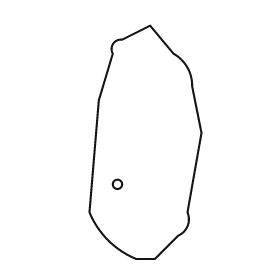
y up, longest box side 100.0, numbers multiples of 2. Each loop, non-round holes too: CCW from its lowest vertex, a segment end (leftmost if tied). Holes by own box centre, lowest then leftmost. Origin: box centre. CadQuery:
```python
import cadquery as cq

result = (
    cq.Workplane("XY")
    .moveTo(-4.0, -50.0)
    .lineTo(4.0, -50.0)
    .lineTo(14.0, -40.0)
    .threePointArc((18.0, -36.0), (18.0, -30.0))
    .lineTo(24.0, 4.0)
    .lineTo(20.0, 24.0)
    .threePointArc((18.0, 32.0), (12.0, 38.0))
    .lineTo(2.0, 50.0)
    .lineTo(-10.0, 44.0)
    .threePointArc((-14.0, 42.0), (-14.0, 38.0))
    .lineTo(-20.0, 18.0)
    .lineTo(-24.0, -30.0)
    .threePointArc((-16.0, -42.0), (-4.0, -50.0))
    .close()
    .moveTo(-12.0, -18.0)
    .circle(2.0)
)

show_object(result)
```